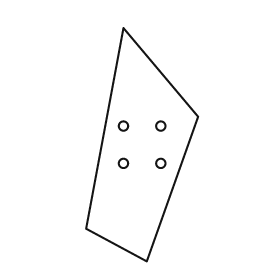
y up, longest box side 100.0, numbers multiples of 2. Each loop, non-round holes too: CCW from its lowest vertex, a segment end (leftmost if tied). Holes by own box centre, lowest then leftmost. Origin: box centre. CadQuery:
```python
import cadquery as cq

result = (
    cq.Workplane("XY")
    .moveTo(2.0, -50.0)
    .lineTo(24.0, 12.0)
    .lineTo(-8.0, 50.0)
    .lineTo(-24.0, -36.0)
    .close()
    .moveTo(-8.0, -8.0)
    .circle(2.0)
    .moveTo(8.0, -8.0)
    .circle(2.0)
    .moveTo(-8.0, 8.0)
    .circle(2.0)
    .moveTo(8.0, 8.0)
    .circle(2.0)
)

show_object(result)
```